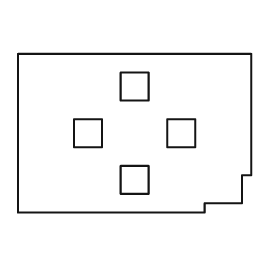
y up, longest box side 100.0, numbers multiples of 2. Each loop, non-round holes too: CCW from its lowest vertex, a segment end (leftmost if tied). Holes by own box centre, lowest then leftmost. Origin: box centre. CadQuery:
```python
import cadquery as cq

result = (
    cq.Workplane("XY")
    .moveTo(-50.0, -34.0)
    .lineTo(30.0, -34.0)
    .lineTo(30.0, -30.0)
    .lineTo(46.0, -30.0)
    .lineTo(46.0, -18.0)
    .lineTo(50.0, -18.0)
    .lineTo(50.0, 34.0)
    .lineTo(-50.0, 34.0)
    .close()
    .moveTo(-6.0, -26.0)
    .lineTo(6.0, -26.0)
    .lineTo(6.0, -14.0)
    .lineTo(-6.0, -14.0)
    .close()
    .moveTo(-26.0, -6.0)
    .lineTo(-14.0, -6.0)
    .lineTo(-14.0, 6.0)
    .lineTo(-26.0, 6.0)
    .close()
    .moveTo(14.0, -6.0)
    .lineTo(26.0, -6.0)
    .lineTo(26.0, 6.0)
    .lineTo(14.0, 6.0)
    .close()
    .moveTo(-6.0, 14.0)
    .lineTo(6.0, 14.0)
    .lineTo(6.0, 26.0)
    .lineTo(-6.0, 26.0)
    .close()
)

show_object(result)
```